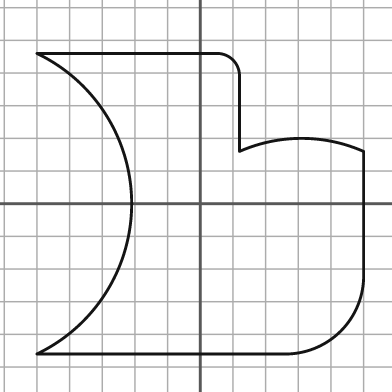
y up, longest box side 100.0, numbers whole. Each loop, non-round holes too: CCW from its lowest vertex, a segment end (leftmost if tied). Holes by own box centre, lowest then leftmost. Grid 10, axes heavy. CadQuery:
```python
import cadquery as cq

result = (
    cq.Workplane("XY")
    .moveTo(-50.0, -46.0)
    .lineTo(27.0, -46.0)
    .threePointArc((43.0, -39.0), (50.0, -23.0))
    .lineTo(50.0, 16.0)
    .threePointArc((31.0, 20.0), (12.0, 16.0))
    .lineTo(12.0, 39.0)
    .threePointArc((10.0, 44.0), (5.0, 46.0))
    .lineTo(-50.0, 46.0)
    .threePointArc((-21.0, 0.0), (-50.0, -46.0))
    .close()
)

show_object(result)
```